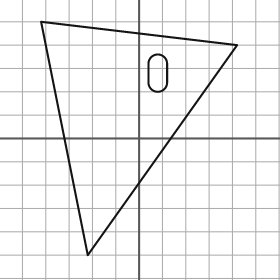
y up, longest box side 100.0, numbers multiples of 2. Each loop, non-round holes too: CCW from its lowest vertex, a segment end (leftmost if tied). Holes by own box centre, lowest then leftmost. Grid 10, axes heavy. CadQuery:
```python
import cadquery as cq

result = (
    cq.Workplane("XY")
    .moveTo(-22.0, -50.0)
    .lineTo(42.0, 40.0)
    .lineTo(-42.0, 50.0)
    .close()
    .moveTo(4.0, 24.0)
    .threePointArc((8.0, 20.0), (12.0, 24.0))
    .lineTo(12.0, 32.0)
    .threePointArc((8.0, 36.0), (4.0, 32.0))
    .close()
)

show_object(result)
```